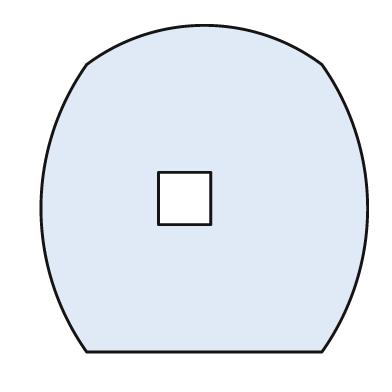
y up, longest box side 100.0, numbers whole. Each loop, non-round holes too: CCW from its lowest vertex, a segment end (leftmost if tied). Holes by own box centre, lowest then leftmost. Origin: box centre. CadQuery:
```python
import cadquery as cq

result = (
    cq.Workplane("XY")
    .moveTo(-36.0, -50.0)
    .lineTo(36.0, -50.0)
    .threePointArc((50.0, -6.0), (36.0, 38.0))
    .threePointArc((0.0, 50.0), (-36.0, 38.0))
    .threePointArc((-50.0, -6.0), (-36.0, -50.0))
    .close()
    .moveTo(-14.0, -11.0)
    .lineTo(2.0, -11.0)
    .lineTo(2.0, 5.0)
    .lineTo(-14.0, 5.0)
    .close()
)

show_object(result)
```